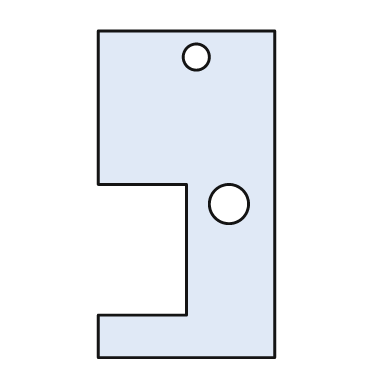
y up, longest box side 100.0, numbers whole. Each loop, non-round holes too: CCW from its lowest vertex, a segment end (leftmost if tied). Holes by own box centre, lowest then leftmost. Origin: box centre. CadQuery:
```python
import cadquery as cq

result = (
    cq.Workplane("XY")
    .moveTo(-27.0, -50.0)
    .lineTo(27.0, -50.0)
    .lineTo(27.0, 50.0)
    .lineTo(-27.0, 50.0)
    .lineTo(-27.0, 3.0)
    .lineTo(0.0, 3.0)
    .lineTo(0.0, -37.0)
    .lineTo(-27.0, -37.0)
    .close()
    .moveTo(13.0, -3.0)
    .circle(6.0)
    .moveTo(3.0, 42.0)
    .circle(4.0)
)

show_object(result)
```